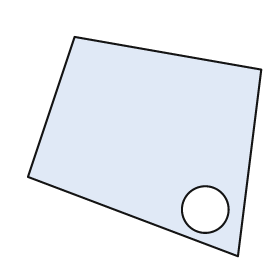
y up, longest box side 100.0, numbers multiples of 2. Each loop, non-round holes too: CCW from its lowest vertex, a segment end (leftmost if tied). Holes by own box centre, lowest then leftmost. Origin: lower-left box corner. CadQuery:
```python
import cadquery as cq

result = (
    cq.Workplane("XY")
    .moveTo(90.0, 0.0)
    .lineTo(100.0, 80.0)
    .lineTo(20.0, 94.0)
    .lineTo(0.0, 34.0)
    .close()
    .moveTo(76.0, 20.0)
    .circle(10.0)
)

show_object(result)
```